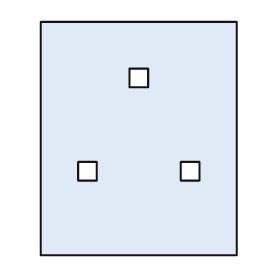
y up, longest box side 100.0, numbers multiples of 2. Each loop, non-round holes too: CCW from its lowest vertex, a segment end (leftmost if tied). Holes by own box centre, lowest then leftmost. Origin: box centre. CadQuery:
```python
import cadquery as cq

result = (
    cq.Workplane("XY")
    .moveTo(-42.0, -50.0)
    .lineTo(42.0, -50.0)
    .lineTo(42.0, 50.0)
    .lineTo(-42.0, 50.0)
    .close()
    .moveTo(-26.0, -18.0)
    .lineTo(-18.0, -18.0)
    .lineTo(-18.0, -10.0)
    .lineTo(-26.0, -10.0)
    .close()
    .moveTo(18.0, -18.0)
    .lineTo(26.0, -18.0)
    .lineTo(26.0, -10.0)
    .lineTo(18.0, -10.0)
    .close()
    .moveTo(-4.0, 22.0)
    .lineTo(4.0, 22.0)
    .lineTo(4.0, 30.0)
    .lineTo(-4.0, 30.0)
    .close()
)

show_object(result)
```